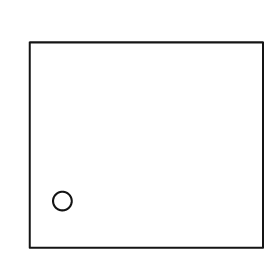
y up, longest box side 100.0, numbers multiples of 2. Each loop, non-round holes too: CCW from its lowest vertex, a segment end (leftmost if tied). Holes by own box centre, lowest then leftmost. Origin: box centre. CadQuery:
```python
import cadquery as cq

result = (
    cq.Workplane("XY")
    .moveTo(-50.0, -44.0)
    .lineTo(50.0, -44.0)
    .lineTo(50.0, 44.0)
    .lineTo(-50.0, 44.0)
    .close()
    .moveTo(-36.0, -24.0)
    .circle(4.0)
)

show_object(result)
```